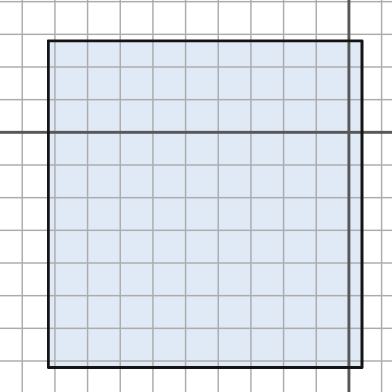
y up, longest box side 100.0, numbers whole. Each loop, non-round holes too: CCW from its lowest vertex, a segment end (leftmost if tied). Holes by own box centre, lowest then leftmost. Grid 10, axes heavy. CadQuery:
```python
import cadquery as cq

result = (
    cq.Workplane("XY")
    .moveTo(-92.0, -72.0)
    .lineTo(4.0, -72.0)
    .lineTo(4.0, 28.0)
    .lineTo(-92.0, 28.0)
    .close()
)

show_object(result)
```